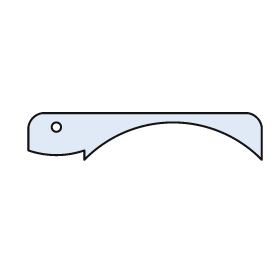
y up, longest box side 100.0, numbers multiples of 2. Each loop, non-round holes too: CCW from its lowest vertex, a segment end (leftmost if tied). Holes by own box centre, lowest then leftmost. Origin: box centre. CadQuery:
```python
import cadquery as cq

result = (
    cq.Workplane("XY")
    .moveTo(-26.0, -10.0)
    .threePointArc((12.0, 6.0), (50.0, -10.0))
    .lineTo(50.0, 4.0)
    .threePointArc((48.0, 8.0), (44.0, 10.0))
    .lineTo(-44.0, 10.0)
    .threePointArc((-48.0, 8.0), (-50.0, 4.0))
    .lineTo(-50.0, -6.0)
    .threePointArc((-38.0, -8.0), (-26.0, -6.0))
    .close()
    .moveTo(-38.0, 4.0)
    .circle(2.0)
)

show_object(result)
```